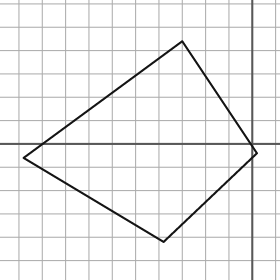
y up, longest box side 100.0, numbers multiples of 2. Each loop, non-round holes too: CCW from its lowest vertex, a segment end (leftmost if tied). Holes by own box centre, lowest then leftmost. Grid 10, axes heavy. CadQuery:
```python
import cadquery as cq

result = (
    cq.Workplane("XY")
    .moveTo(-38.0, -42.0)
    .lineTo(2.0, -4.0)
    .lineTo(-30.0, 44.0)
    .lineTo(-98.0, -6.0)
    .close()
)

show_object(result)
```